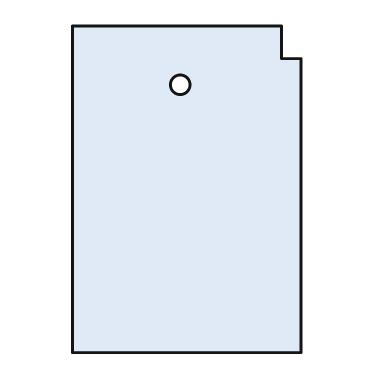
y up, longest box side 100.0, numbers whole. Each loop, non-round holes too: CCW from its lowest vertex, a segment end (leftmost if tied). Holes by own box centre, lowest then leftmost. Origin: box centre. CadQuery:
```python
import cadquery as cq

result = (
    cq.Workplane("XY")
    .moveTo(-35.0, -50.0)
    .lineTo(35.0, -50.0)
    .lineTo(35.0, 40.0)
    .lineTo(29.0, 40.0)
    .lineTo(29.0, 50.0)
    .lineTo(-35.0, 50.0)
    .close()
    .moveTo(-2.0, 32.0)
    .circle(3.0)
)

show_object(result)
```